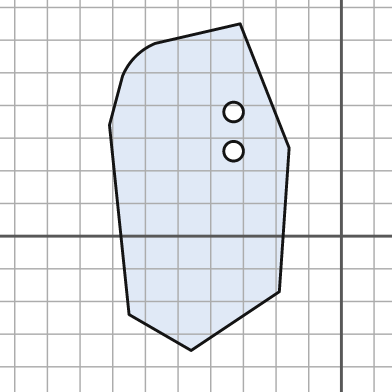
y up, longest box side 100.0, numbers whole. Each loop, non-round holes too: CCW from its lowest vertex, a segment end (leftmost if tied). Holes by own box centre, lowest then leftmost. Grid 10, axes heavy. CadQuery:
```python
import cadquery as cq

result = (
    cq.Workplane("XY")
    .moveTo(-46.0, -35.0)
    .lineTo(-19.0, -17.0)
    .lineTo(-16.0, 27.0)
    .lineTo(-31.0, 65.0)
    .lineTo(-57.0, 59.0)
    .threePointArc((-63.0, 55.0), (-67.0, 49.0))
    .lineTo(-71.0, 34.0)
    .lineTo(-65.0, -24.0)
    .close()
    .moveTo(-33.0, 26.0)
    .circle(3.0)
    .moveTo(-33.0, 38.0)
    .circle(3.0)
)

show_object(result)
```